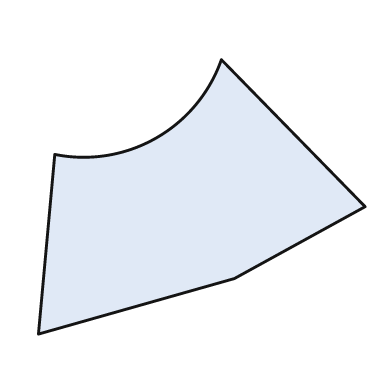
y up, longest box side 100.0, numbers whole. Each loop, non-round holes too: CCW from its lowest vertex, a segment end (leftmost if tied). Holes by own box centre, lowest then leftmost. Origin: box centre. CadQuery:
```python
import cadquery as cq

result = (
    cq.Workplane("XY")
    .moveTo(-50.0, -42.0)
    .lineTo(10.0, -25.0)
    .lineTo(50.0, -3.0)
    .lineTo(6.0, 42.0)
    .threePointArc((-14.0, 18.0), (-45.0, 13.0))
    .close()
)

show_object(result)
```